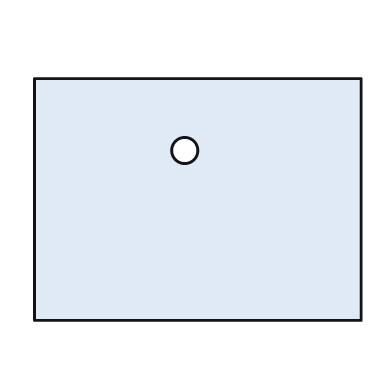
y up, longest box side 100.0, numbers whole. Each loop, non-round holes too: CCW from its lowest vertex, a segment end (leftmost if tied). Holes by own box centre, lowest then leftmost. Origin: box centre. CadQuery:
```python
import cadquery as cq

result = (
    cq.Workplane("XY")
    .moveTo(-50.0, -37.0)
    .lineTo(50.0, -37.0)
    .lineTo(50.0, 37.0)
    .lineTo(-50.0, 37.0)
    .close()
    .moveTo(-4.0, 15.0)
    .circle(4.0)
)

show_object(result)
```